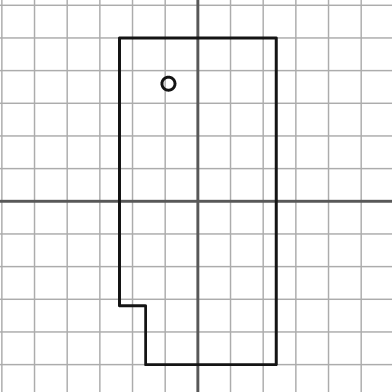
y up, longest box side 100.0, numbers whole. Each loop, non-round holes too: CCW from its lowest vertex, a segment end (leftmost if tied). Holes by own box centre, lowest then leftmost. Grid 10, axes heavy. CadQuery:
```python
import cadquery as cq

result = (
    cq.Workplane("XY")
    .moveTo(-16.0, -50.0)
    .lineTo(24.0, -50.0)
    .lineTo(24.0, 50.0)
    .lineTo(-24.0, 50.0)
    .lineTo(-24.0, -32.0)
    .lineTo(-16.0, -32.0)
    .close()
    .moveTo(-9.0, 36.0)
    .circle(2.0)
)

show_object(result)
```